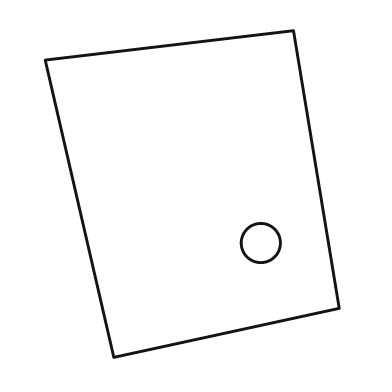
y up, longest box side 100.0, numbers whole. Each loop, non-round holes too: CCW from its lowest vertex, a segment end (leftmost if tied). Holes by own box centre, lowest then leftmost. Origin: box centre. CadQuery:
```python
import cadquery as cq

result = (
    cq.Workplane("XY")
    .moveTo(-24.0, -50.0)
    .lineTo(45.0, -35.0)
    .lineTo(31.0, 50.0)
    .lineTo(-45.0, 41.0)
    .close()
    .moveTo(21.0, -15.0)
    .circle(6.0)
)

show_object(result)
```